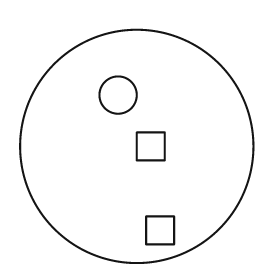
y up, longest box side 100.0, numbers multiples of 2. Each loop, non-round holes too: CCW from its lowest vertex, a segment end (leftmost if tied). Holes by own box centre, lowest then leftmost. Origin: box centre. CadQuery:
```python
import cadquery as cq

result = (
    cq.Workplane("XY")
    .moveTo(0.0, 0.0)
    .circle(50.0)
    .moveTo(4.0, -42.0)
    .lineTo(16.0, -42.0)
    .lineTo(16.0, -30.0)
    .lineTo(4.0, -30.0)
    .close()
    .moveTo(0.0, -6.0)
    .lineTo(12.0, -6.0)
    .lineTo(12.0, 6.0)
    .lineTo(0.0, 6.0)
    .close()
    .moveTo(-8.0, 22.0)
    .circle(8.0)
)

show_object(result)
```